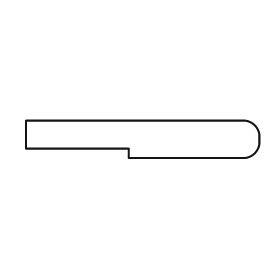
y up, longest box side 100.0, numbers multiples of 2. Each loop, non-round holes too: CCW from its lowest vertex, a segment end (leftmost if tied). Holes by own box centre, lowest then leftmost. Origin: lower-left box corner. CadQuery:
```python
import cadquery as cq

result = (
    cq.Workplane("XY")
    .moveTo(44.0, 0.0)
    .lineTo(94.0, 0.0)
    .threePointArc((98.0, 2.0), (100.0, 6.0))
    .lineTo(100.0, 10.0)
    .threePointArc((98.0, 14.0), (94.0, 16.0))
    .lineTo(0.0, 16.0)
    .lineTo(0.0, 4.0)
    .lineTo(44.0, 4.0)
    .close()
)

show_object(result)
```